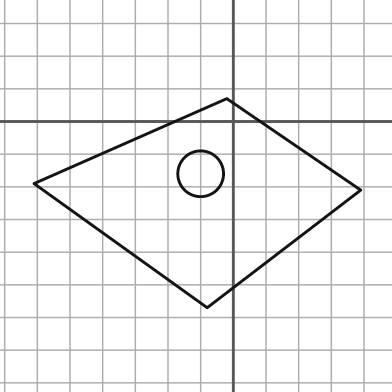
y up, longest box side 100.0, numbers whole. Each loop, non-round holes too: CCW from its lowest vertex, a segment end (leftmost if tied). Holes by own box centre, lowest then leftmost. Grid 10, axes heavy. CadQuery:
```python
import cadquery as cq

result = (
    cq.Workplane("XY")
    .moveTo(-8.0, -57.0)
    .lineTo(39.0, -21.0)
    .lineTo(-2.0, 7.0)
    .lineTo(-61.0, -19.0)
    .close()
    .moveTo(-10.0, -16.0)
    .circle(7.0)
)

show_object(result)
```